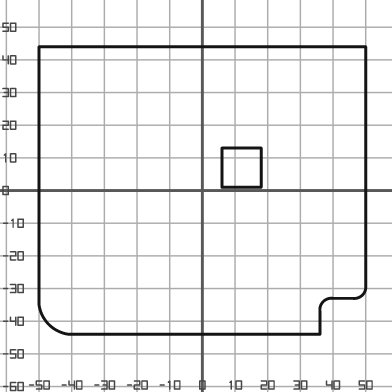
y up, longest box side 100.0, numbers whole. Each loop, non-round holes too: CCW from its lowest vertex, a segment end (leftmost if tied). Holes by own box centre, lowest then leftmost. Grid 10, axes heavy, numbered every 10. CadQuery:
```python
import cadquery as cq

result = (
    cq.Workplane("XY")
    .moveTo(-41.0, -44.0)
    .lineTo(36.0, -44.0)
    .lineTo(36.0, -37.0)
    .threePointArc((37.0, -34.0), (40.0, -33.0))
    .lineTo(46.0, -33.0)
    .threePointArc((49.0, -32.0), (50.0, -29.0))
    .lineTo(50.0, 44.0)
    .lineTo(-50.0, 44.0)
    .lineTo(-50.0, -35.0)
    .threePointArc((-47.0, -41.0), (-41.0, -44.0))
    .close()
    .moveTo(6.0, 1.0)
    .lineTo(18.0, 1.0)
    .lineTo(18.0, 13.0)
    .lineTo(6.0, 13.0)
    .close()
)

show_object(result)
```